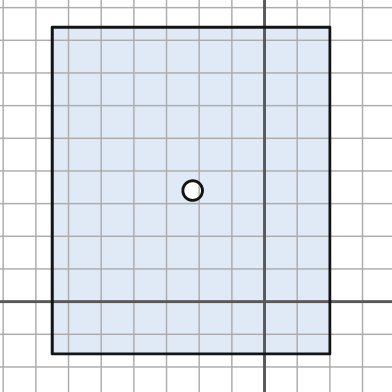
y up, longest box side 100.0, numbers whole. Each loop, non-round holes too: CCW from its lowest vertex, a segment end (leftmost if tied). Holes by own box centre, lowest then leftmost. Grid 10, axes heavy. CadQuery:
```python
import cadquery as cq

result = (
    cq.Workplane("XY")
    .moveTo(-65.0, -16.0)
    .lineTo(20.0, -16.0)
    .lineTo(20.0, 84.0)
    .lineTo(-65.0, 84.0)
    .close()
    .moveTo(-22.0, 34.0)
    .circle(3.0)
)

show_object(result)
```